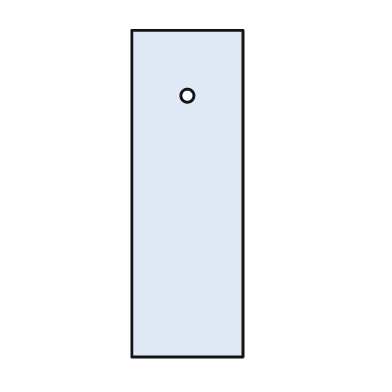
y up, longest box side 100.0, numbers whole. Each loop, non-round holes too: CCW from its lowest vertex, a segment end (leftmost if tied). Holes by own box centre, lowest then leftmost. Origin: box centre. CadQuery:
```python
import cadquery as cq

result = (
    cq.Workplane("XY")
    .moveTo(-17.0, -50.0)
    .lineTo(17.0, -50.0)
    .lineTo(17.0, 50.0)
    .lineTo(-17.0, 50.0)
    .close()
    .moveTo(0.0, 30.0)
    .circle(2.0)
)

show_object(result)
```